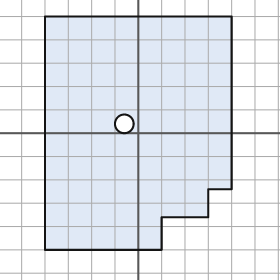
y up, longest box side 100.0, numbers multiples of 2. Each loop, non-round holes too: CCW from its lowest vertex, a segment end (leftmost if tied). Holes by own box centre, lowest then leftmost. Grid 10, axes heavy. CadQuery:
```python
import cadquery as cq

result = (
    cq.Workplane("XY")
    .moveTo(-40.0, -50.0)
    .lineTo(10.0, -50.0)
    .lineTo(10.0, -36.0)
    .lineTo(30.0, -36.0)
    .lineTo(30.0, -24.0)
    .lineTo(40.0, -24.0)
    .lineTo(40.0, 50.0)
    .lineTo(-40.0, 50.0)
    .close()
    .moveTo(-6.0, 4.0)
    .circle(4.0)
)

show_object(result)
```